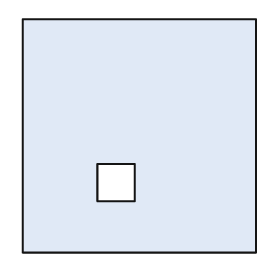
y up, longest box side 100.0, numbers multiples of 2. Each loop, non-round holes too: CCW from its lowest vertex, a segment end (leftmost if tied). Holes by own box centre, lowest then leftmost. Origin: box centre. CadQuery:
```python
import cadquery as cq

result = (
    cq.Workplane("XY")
    .moveTo(-50.0, -50.0)
    .lineTo(50.0, -50.0)
    .lineTo(50.0, 50.0)
    .lineTo(-50.0, 50.0)
    .close()
    .moveTo(-18.0, -28.0)
    .lineTo(-2.0, -28.0)
    .lineTo(-2.0, -12.0)
    .lineTo(-18.0, -12.0)
    .close()
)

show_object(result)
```